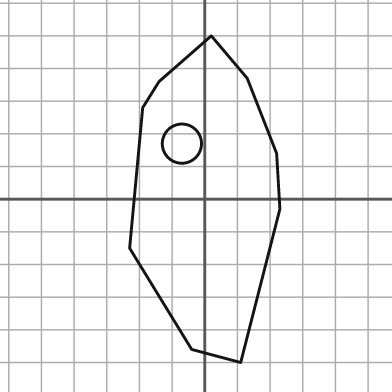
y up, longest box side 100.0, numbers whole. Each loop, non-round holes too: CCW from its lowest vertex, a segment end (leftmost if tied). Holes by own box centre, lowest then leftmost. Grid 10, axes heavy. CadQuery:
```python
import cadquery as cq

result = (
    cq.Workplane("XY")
    .moveTo(11.0, -50.0)
    .lineTo(23.0, -3.0)
    .lineTo(22.0, 14.0)
    .lineTo(13.0, 37.0)
    .lineTo(2.0, 50.0)
    .lineTo(-14.0, 36.0)
    .lineTo(-19.0, 28.0)
    .lineTo(-23.0, -15.0)
    .lineTo(-4.0, -46.0)
    .close()
    .moveTo(-7.0, 17.0)
    .circle(6.0)
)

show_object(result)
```